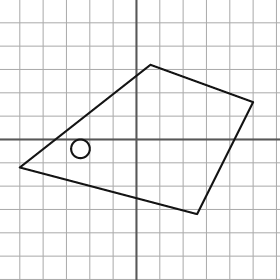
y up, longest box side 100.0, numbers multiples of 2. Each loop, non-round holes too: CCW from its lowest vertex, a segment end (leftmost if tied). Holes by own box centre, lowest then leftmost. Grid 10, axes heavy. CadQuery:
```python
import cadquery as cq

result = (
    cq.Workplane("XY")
    .moveTo(26.0, -32.0)
    .lineTo(50.0, 16.0)
    .lineTo(6.0, 32.0)
    .lineTo(-50.0, -12.0)
    .close()
    .moveTo(-24.0, -4.0)
    .circle(4.0)
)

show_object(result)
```